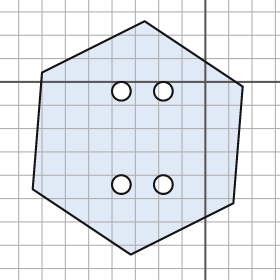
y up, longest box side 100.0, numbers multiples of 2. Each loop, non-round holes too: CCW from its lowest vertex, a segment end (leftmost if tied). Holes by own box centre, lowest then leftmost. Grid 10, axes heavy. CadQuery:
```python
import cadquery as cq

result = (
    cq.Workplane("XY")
    .moveTo(-32.0, -74.0)
    .lineTo(12.0, -52.0)
    .lineTo(16.0, -2.0)
    .lineTo(-26.0, 26.0)
    .lineTo(-70.0, 4.0)
    .lineTo(-74.0, -46.0)
    .close()
    .moveTo(-36.0, -44.0)
    .circle(4.0)
    .moveTo(-18.0, -44.0)
    .circle(4.0)
    .moveTo(-36.0, -4.0)
    .circle(4.0)
    .moveTo(-18.0, -4.0)
    .circle(4.0)
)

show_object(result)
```